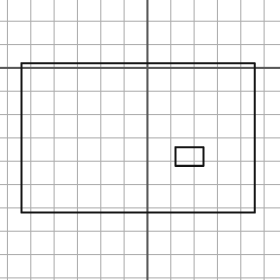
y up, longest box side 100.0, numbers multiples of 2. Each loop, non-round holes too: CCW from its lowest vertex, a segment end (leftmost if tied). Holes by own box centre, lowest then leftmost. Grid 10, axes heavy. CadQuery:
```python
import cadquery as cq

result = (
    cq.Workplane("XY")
    .moveTo(-54.0, -62.0)
    .lineTo(46.0, -62.0)
    .lineTo(46.0, 2.0)
    .lineTo(-54.0, 2.0)
    .close()
    .moveTo(12.0, -42.0)
    .lineTo(24.0, -42.0)
    .lineTo(24.0, -34.0)
    .lineTo(12.0, -34.0)
    .close()
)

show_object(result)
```